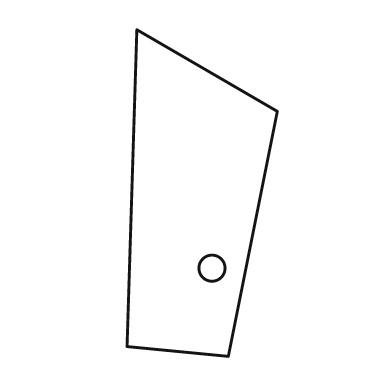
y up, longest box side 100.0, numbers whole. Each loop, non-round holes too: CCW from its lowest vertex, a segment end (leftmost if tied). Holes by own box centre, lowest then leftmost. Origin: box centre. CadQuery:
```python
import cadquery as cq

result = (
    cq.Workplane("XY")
    .moveTo(8.0, -50.0)
    .lineTo(23.0, 25.0)
    .lineTo(-20.0, 50.0)
    .lineTo(-23.0, -47.0)
    .close()
    .moveTo(3.0, -23.0)
    .circle(4.0)
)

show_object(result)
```